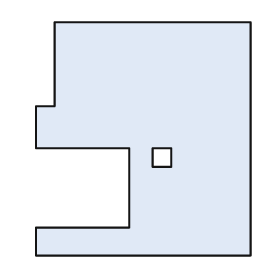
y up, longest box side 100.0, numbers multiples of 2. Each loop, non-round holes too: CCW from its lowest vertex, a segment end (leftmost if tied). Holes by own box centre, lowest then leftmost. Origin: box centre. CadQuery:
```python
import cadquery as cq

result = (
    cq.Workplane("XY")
    .moveTo(-46.0, -50.0)
    .lineTo(46.0, -50.0)
    .lineTo(46.0, 50.0)
    .lineTo(-38.0, 50.0)
    .lineTo(-38.0, 14.0)
    .lineTo(-46.0, 14.0)
    .lineTo(-46.0, -4.0)
    .lineTo(-6.0, -4.0)
    .lineTo(-6.0, -38.0)
    .lineTo(-46.0, -38.0)
    .close()
    .moveTo(4.0, -12.0)
    .lineTo(12.0, -12.0)
    .lineTo(12.0, -4.0)
    .lineTo(4.0, -4.0)
    .close()
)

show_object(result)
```